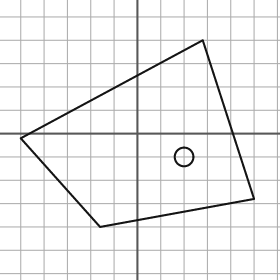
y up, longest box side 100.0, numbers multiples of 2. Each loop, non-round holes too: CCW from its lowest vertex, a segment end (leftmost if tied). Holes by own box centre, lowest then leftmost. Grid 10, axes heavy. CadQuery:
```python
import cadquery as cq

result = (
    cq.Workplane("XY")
    .moveTo(-16.0, -40.0)
    .lineTo(50.0, -28.0)
    .lineTo(28.0, 40.0)
    .lineTo(-50.0, -2.0)
    .close()
    .moveTo(20.0, -10.0)
    .circle(4.0)
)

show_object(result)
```